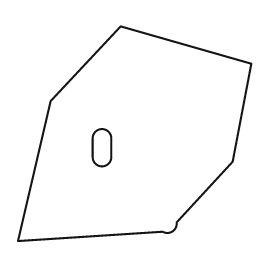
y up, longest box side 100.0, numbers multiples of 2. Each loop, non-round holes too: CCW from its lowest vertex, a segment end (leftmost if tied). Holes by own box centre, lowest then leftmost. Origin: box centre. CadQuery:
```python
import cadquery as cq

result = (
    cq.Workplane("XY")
    .moveTo(-50.0, -46.0)
    .lineTo(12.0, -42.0)
    .threePointArc((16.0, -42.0), (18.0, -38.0))
    .lineTo(42.0, -12.0)
    .lineTo(50.0, 30.0)
    .lineTo(-6.0, 46.0)
    .lineTo(-36.0, 14.0)
    .close()
    .moveTo(-18.0, -10.0)
    .threePointArc((-14.0, -14.0), (-10.0, -10.0))
    .lineTo(-10.0, -2.0)
    .threePointArc((-14.0, 2.0), (-18.0, -2.0))
    .close()
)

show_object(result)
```